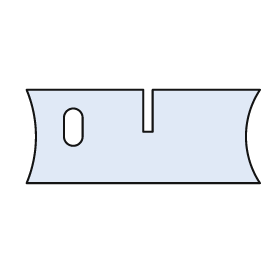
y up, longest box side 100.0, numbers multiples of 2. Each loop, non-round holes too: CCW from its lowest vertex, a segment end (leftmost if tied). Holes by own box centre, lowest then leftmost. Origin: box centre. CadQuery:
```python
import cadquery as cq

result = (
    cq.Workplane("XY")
    .moveTo(-50.0, -20.0)
    .lineTo(50.0, -20.0)
    .threePointArc((44.0, 0.0), (50.0, 20.0))
    .lineTo(4.0, 20.0)
    .lineTo(4.0, 2.0)
    .lineTo(0.0, 2.0)
    .lineTo(0.0, 20.0)
    .lineTo(-50.0, 20.0)
    .threePointArc((-46.0, 0.0), (-50.0, -20.0))
    .close()
    .moveTo(-34.0, 0.0)
    .threePointArc((-30.0, -4.0), (-26.0, 0.0))
    .lineTo(-26.0, 8.0)
    .threePointArc((-30.0, 12.0), (-34.0, 8.0))
    .close()
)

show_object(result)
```